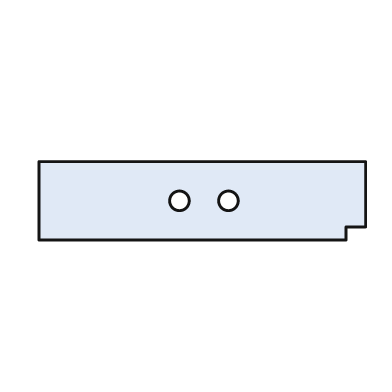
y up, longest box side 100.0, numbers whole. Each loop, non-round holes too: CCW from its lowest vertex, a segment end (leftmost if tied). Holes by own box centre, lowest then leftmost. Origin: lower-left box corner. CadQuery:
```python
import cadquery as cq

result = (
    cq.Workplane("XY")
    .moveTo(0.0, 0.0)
    .lineTo(94.0, 0.0)
    .lineTo(94.0, 4.0)
    .lineTo(100.0, 4.0)
    .lineTo(100.0, 24.0)
    .lineTo(0.0, 24.0)
    .close()
    .moveTo(43.0, 12.0)
    .circle(3.0)
    .moveTo(58.0, 12.0)
    .circle(3.0)
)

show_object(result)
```